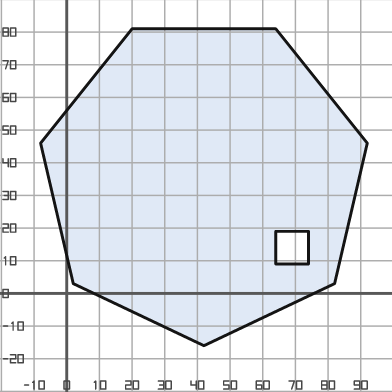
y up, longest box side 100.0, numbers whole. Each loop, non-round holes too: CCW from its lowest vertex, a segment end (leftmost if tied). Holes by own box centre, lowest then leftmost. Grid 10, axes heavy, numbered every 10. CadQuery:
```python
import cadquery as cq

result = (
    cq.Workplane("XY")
    .moveTo(42.0, -16.0)
    .lineTo(82.0, 3.0)
    .lineTo(92.0, 46.0)
    .lineTo(64.0, 81.0)
    .lineTo(20.0, 81.0)
    .lineTo(-8.0, 46.0)
    .lineTo(2.0, 3.0)
    .close()
    .moveTo(64.0, 9.0)
    .lineTo(74.0, 9.0)
    .lineTo(74.0, 19.0)
    .lineTo(64.0, 19.0)
    .close()
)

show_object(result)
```